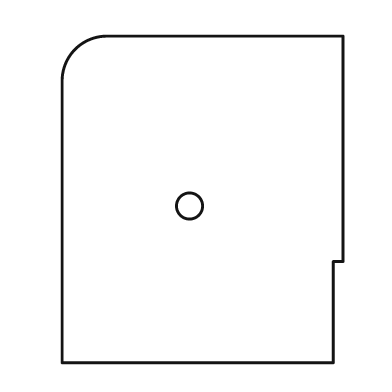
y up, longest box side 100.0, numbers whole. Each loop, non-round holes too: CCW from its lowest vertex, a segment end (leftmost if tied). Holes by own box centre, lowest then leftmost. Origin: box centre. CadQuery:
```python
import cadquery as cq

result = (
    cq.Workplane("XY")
    .moveTo(-43.0, -50.0)
    .lineTo(40.0, -50.0)
    .lineTo(40.0, -19.0)
    .lineTo(43.0, -19.0)
    .lineTo(43.0, 50.0)
    .lineTo(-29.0, 50.0)
    .threePointArc((-39.0, 46.0), (-43.0, 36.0))
    .close()
    .moveTo(-4.0, -2.0)
    .circle(4.0)
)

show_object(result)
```